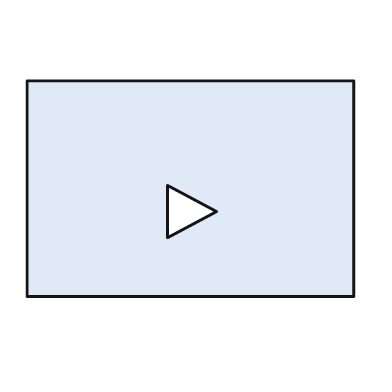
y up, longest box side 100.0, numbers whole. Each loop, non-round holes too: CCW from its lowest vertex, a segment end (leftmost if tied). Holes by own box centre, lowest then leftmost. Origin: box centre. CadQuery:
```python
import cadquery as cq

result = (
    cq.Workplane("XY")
    .moveTo(-50.0, -33.0)
    .lineTo(50.0, -33.0)
    .lineTo(50.0, 33.0)
    .lineTo(-50.0, 33.0)
    .close()
    .moveTo(-7.0, -15.0)
    .lineTo(8.0, -7.0)
    .lineTo(-7.0, 1.0)
    .close()
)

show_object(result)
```